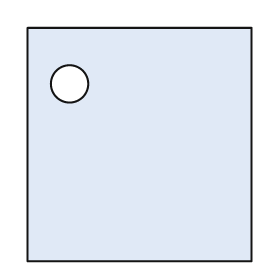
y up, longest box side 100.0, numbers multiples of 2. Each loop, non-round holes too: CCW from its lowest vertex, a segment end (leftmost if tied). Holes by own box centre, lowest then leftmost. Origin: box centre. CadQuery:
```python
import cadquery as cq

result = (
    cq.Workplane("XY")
    .moveTo(-48.0, -50.0)
    .lineTo(48.0, -50.0)
    .lineTo(48.0, 50.0)
    .lineTo(-48.0, 50.0)
    .close()
    .moveTo(-30.0, 26.0)
    .circle(8.0)
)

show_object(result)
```